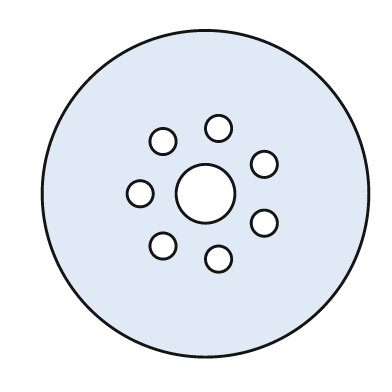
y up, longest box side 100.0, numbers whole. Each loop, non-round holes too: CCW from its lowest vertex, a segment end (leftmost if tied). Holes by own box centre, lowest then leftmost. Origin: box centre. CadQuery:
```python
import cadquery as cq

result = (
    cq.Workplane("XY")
    .moveTo(0.0, 0.0)
    .circle(50.0)
    .moveTo(4.0, -20.0)
    .circle(4.0)
    .moveTo(-13.0, -16.0)
    .circle(4.0)
    .moveTo(18.0, -9.0)
    .circle(4.0)
    .moveTo(-20.0, 0.0)
    .circle(4.0)
    .moveTo(0.0, 0.0)
    .circle(9.0)
    .moveTo(18.0, 9.0)
    .circle(4.0)
    .moveTo(-13.0, 16.0)
    .circle(4.0)
    .moveTo(4.0, 20.0)
    .circle(4.0)
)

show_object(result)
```